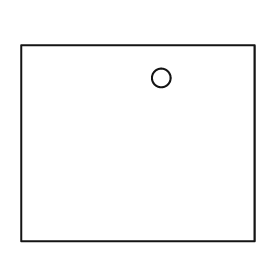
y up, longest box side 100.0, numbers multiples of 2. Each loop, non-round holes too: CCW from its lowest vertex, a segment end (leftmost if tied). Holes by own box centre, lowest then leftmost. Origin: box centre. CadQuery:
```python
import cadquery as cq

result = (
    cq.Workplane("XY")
    .moveTo(-50.0, -42.0)
    .lineTo(50.0, -42.0)
    .lineTo(50.0, 42.0)
    .lineTo(-50.0, 42.0)
    .close()
    .moveTo(10.0, 28.0)
    .circle(4.0)
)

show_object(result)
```